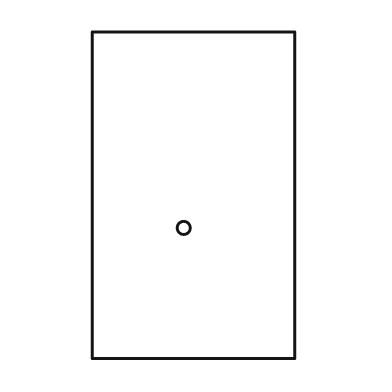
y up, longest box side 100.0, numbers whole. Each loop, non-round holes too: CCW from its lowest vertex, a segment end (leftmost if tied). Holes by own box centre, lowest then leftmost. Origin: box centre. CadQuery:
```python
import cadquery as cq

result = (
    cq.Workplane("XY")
    .moveTo(-31.0, -50.0)
    .lineTo(31.0, -50.0)
    .lineTo(31.0, 50.0)
    .lineTo(-31.0, 50.0)
    .close()
    .moveTo(-3.0, -10.0)
    .circle(2.0)
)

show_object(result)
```